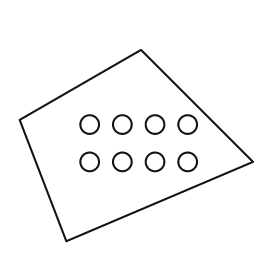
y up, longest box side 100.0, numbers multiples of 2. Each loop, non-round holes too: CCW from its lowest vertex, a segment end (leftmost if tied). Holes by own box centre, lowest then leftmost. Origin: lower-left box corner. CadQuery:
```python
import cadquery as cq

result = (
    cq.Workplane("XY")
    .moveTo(20.0, 0.0)
    .lineTo(100.0, 34.0)
    .lineTo(52.0, 82.0)
    .lineTo(0.0, 52.0)
    .close()
    .moveTo(30.0, 34.0)
    .circle(4.0)
    .moveTo(44.0, 34.0)
    .circle(4.0)
    .moveTo(58.0, 34.0)
    .circle(4.0)
    .moveTo(72.0, 34.0)
    .circle(4.0)
    .moveTo(30.0, 50.0)
    .circle(4.0)
    .moveTo(44.0, 50.0)
    .circle(4.0)
    .moveTo(58.0, 50.0)
    .circle(4.0)
    .moveTo(72.0, 50.0)
    .circle(4.0)
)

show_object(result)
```